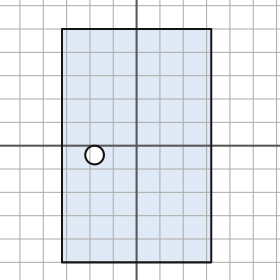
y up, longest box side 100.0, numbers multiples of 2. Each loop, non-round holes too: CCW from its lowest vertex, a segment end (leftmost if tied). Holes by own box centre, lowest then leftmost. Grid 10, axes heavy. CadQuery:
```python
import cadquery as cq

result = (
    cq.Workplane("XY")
    .moveTo(-32.0, -50.0)
    .lineTo(32.0, -50.0)
    .lineTo(32.0, 50.0)
    .lineTo(-32.0, 50.0)
    .close()
    .moveTo(-18.0, -4.0)
    .circle(4.0)
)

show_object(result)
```